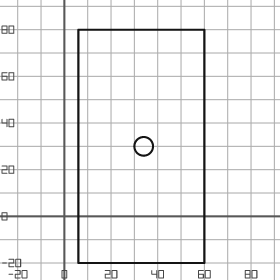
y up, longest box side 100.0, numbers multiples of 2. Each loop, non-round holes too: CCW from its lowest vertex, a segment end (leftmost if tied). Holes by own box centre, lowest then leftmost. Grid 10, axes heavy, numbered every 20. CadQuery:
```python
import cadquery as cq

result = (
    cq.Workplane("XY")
    .moveTo(6.0, -20.0)
    .lineTo(60.0, -20.0)
    .lineTo(60.0, 80.0)
    .lineTo(6.0, 80.0)
    .close()
    .moveTo(34.0, 30.0)
    .circle(4.0)
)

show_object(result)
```